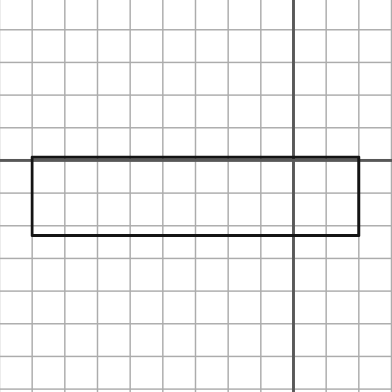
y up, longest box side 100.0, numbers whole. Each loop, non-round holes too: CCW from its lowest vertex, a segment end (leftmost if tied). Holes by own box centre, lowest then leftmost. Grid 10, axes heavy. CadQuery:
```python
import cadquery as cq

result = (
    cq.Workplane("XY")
    .moveTo(-80.0, -23.0)
    .lineTo(20.0, -23.0)
    .lineTo(20.0, 1.0)
    .lineTo(-80.0, 1.0)
    .close()
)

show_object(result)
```